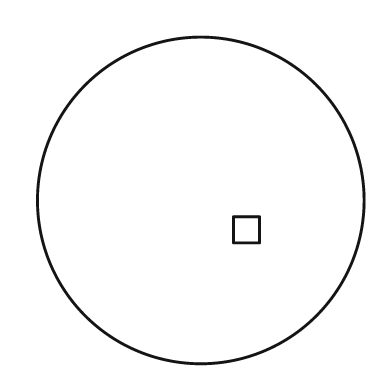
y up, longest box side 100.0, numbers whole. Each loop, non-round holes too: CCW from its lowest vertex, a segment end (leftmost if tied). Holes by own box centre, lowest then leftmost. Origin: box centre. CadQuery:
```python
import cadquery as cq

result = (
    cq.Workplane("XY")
    .moveTo(0.0, 0.0)
    .circle(50.0)
    .moveTo(10.0, -13.0)
    .lineTo(18.0, -13.0)
    .lineTo(18.0, -5.0)
    .lineTo(10.0, -5.0)
    .close()
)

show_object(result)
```